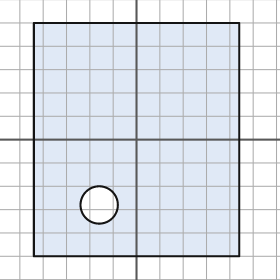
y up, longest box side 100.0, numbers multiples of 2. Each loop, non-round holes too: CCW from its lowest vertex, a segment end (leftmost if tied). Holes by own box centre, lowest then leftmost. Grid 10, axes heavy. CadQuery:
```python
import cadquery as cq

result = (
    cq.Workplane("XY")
    .moveTo(-44.0, -50.0)
    .lineTo(44.0, -50.0)
    .lineTo(44.0, 50.0)
    .lineTo(-44.0, 50.0)
    .close()
    .moveTo(-16.0, -28.0)
    .circle(8.0)
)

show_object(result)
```